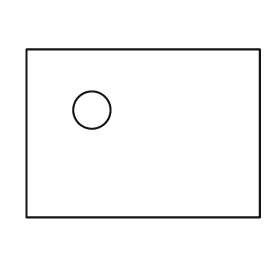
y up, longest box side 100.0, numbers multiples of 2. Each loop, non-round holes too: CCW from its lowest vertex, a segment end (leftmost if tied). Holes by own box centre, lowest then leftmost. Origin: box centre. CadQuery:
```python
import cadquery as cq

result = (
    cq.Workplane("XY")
    .moveTo(-50.0, -36.0)
    .lineTo(50.0, -36.0)
    .lineTo(50.0, 36.0)
    .lineTo(-50.0, 36.0)
    .close()
    .moveTo(-22.0, 10.0)
    .circle(8.0)
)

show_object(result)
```